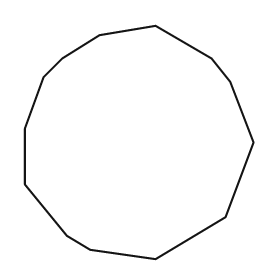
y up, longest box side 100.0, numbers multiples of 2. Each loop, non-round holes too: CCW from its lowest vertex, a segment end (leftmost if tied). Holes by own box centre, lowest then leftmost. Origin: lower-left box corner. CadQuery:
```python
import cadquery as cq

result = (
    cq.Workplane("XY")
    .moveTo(56.0, 0.0)
    .lineTo(86.0, 18.0)
    .lineTo(98.0, 50.0)
    .lineTo(88.0, 76.0)
    .lineTo(80.0, 86.0)
    .lineTo(56.0, 100.0)
    .lineTo(32.0, 96.0)
    .lineTo(16.0, 86.0)
    .lineTo(8.0, 78.0)
    .lineTo(0.0, 56.0)
    .lineTo(0.0, 32.0)
    .lineTo(18.0, 10.0)
    .lineTo(28.0, 4.0)
    .close()
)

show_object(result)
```